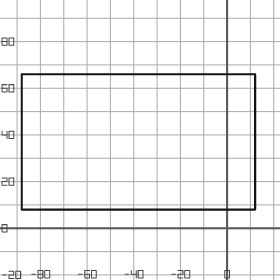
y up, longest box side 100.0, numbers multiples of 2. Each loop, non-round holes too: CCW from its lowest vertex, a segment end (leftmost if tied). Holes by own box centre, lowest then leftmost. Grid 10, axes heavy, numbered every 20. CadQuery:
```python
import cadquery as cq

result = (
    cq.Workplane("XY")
    .moveTo(-88.0, 8.0)
    .lineTo(12.0, 8.0)
    .lineTo(12.0, 66.0)
    .lineTo(-88.0, 66.0)
    .close()
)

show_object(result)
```